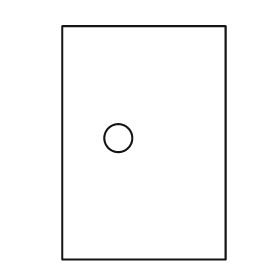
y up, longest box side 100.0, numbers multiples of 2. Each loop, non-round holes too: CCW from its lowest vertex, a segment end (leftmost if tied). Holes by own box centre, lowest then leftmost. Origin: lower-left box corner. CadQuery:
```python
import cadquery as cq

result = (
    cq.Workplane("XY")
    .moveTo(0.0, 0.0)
    .lineTo(70.0, 0.0)
    .lineTo(70.0, 100.0)
    .lineTo(0.0, 100.0)
    .close()
    .moveTo(24.0, 52.0)
    .circle(6.0)
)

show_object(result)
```